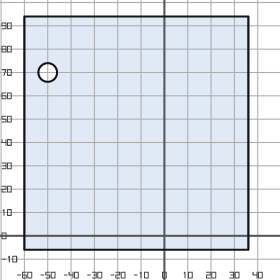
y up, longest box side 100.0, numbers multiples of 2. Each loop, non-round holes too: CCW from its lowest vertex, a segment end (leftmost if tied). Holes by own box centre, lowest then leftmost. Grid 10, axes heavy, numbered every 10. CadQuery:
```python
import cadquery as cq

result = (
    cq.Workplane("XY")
    .moveTo(-60.0, -6.0)
    .lineTo(36.0, -6.0)
    .lineTo(36.0, 94.0)
    .lineTo(-60.0, 94.0)
    .close()
    .moveTo(-50.0, 70.0)
    .circle(4.0)
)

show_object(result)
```